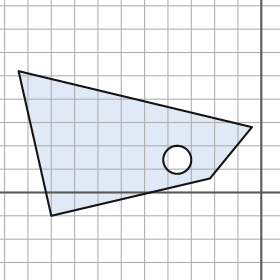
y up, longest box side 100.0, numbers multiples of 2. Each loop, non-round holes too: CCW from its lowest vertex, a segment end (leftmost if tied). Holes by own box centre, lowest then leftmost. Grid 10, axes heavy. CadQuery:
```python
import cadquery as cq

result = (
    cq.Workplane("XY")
    .moveTo(-90.0, -10.0)
    .lineTo(-22.0, 6.0)
    .lineTo(-4.0, 28.0)
    .lineTo(-104.0, 52.0)
    .close()
    .moveTo(-36.0, 14.0)
    .circle(6.0)
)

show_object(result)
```